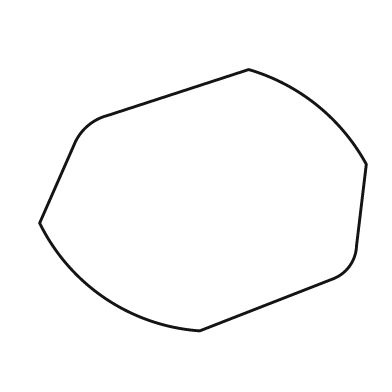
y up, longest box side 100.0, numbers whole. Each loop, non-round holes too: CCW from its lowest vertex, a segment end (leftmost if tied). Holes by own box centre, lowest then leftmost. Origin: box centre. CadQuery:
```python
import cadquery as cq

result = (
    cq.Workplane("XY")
    .moveTo(-1.0, -40.0)
    .lineTo(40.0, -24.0)
    .threePointArc((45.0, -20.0), (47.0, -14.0))
    .lineTo(50.0, 11.0)
    .threePointArc((35.0, 29.0), (14.0, 40.0))
    .lineTo(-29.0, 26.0)
    .threePointArc((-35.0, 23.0), (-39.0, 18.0))
    .lineTo(-50.0, -7.0)
    .threePointArc((-30.0, -30.0), (-1.0, -40.0))
    .close()
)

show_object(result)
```